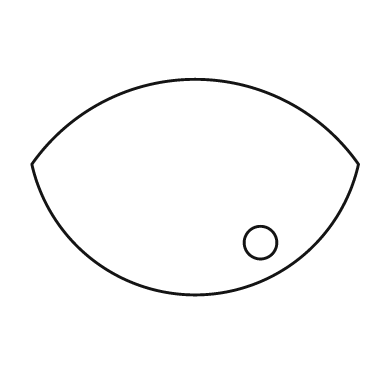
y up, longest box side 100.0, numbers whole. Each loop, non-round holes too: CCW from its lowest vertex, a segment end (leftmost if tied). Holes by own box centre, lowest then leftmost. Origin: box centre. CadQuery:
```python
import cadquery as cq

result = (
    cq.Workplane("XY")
    .moveTo(-50.0, 7.0)
    .threePointArc((0.0, -33.0), (50.0, 7.0))
    .threePointArc((0.0, 33.0), (-50.0, 7.0))
    .close()
    .moveTo(20.0, -17.0)
    .circle(5.0)
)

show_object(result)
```